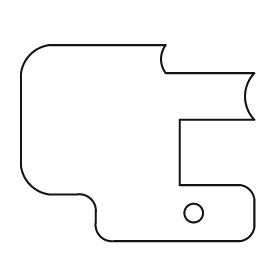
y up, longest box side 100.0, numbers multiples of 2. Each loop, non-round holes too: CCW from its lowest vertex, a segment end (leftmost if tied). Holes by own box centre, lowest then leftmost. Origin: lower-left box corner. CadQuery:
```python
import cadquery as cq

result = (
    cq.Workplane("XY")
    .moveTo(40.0, 0.0)
    .lineTo(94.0, 0.0)
    .threePointArc((98.0, 2.0), (100.0, 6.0))
    .lineTo(100.0, 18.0)
    .threePointArc((98.0, 22.0), (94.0, 24.0))
    .lineTo(68.0, 24.0)
    .lineTo(68.0, 52.0)
    .lineTo(100.0, 52.0)
    .threePointArc((96.0, 62.0), (100.0, 72.0))
    .lineTo(62.0, 72.0)
    .threePointArc((60.0, 78.0), (62.0, 84.0))
    .lineTo(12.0, 84.0)
    .threePointArc((4.0, 80.0), (0.0, 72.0))
    .lineTo(0.0, 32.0)
    .threePointArc((4.0, 24.0), (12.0, 20.0))
    .lineTo(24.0, 20.0)
    .threePointArc((30.0, 18.0), (32.0, 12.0))
    .lineTo(32.0, 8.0)
    .threePointArc((34.0, 2.0), (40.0, 0.0))
    .close()
    .moveTo(74.0, 12.0)
    .circle(4.0)
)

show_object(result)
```